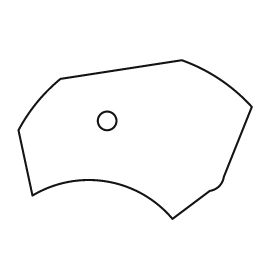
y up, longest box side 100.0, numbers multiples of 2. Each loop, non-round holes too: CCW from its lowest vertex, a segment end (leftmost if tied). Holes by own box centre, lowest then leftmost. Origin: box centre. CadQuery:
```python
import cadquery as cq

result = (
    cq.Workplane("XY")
    .moveTo(16.0, -34.0)
    .lineTo(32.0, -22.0)
    .threePointArc((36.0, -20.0), (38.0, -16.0))
    .lineTo(50.0, 14.0)
    .threePointArc((36.0, 26.0), (20.0, 34.0))
    .lineTo(-32.0, 26.0)
    .threePointArc((-42.0, 16.0), (-50.0, 4.0))
    .lineTo(-44.0, -24.0)
    .threePointArc((-12.0, -18.0), (16.0, -34.0))
    .close()
    .moveTo(-12.0, 8.0)
    .circle(4.0)
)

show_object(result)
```